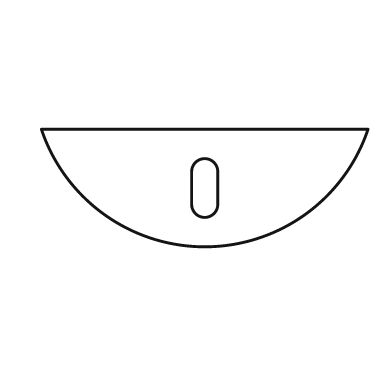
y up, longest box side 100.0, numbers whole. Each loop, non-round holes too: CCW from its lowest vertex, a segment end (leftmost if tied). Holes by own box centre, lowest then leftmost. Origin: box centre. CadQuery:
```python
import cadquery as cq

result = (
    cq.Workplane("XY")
    .moveTo(-50.0, 18.0)
    .threePointArc((0.0, -18.0), (50.0, 18.0))
    .close()
    .moveTo(-4.0, -5.0)
    .threePointArc((0.0, -9.0), (4.0, -5.0))
    .lineTo(4.0, 5.0)
    .threePointArc((0.0, 9.0), (-4.0, 5.0))
    .close()
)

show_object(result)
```